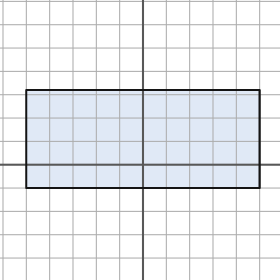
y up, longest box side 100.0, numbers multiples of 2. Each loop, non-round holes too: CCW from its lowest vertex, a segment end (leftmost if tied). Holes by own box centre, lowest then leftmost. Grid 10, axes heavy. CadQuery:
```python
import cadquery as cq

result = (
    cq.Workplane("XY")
    .moveTo(-50.0, -10.0)
    .lineTo(50.0, -10.0)
    .lineTo(50.0, 32.0)
    .lineTo(-50.0, 32.0)
    .close()
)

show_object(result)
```